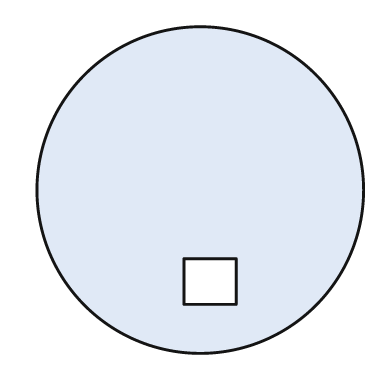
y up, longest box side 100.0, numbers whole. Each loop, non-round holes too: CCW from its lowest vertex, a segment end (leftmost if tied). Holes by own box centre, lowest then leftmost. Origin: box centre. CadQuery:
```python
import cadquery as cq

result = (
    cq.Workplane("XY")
    .moveTo(0.0, 0.0)
    .circle(50.0)
    .moveTo(-5.0, -35.0)
    .lineTo(11.0, -35.0)
    .lineTo(11.0, -21.0)
    .lineTo(-5.0, -21.0)
    .close()
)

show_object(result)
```